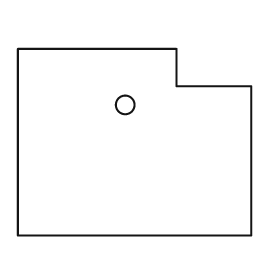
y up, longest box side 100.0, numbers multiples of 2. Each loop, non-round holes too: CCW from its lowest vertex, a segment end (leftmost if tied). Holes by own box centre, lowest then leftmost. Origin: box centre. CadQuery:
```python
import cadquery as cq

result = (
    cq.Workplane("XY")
    .moveTo(-50.0, -40.0)
    .lineTo(50.0, -40.0)
    .lineTo(50.0, 24.0)
    .lineTo(18.0, 24.0)
    .lineTo(18.0, 40.0)
    .lineTo(-50.0, 40.0)
    .close()
    .moveTo(-4.0, 16.0)
    .circle(4.0)
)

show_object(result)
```